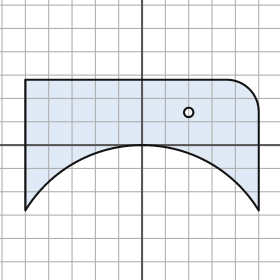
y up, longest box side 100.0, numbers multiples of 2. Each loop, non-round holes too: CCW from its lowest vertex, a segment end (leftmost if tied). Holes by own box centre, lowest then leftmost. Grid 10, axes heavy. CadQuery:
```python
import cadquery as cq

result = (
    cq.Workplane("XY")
    .moveTo(-50.0, -28.0)
    .threePointArc((0.0, 0.0), (50.0, -28.0))
    .lineTo(50.0, 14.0)
    .threePointArc((46.0, 24.0), (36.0, 28.0))
    .lineTo(-50.0, 28.0)
    .close()
    .moveTo(20.0, 14.0)
    .circle(2.0)
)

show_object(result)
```